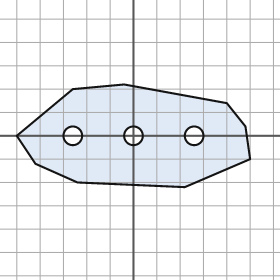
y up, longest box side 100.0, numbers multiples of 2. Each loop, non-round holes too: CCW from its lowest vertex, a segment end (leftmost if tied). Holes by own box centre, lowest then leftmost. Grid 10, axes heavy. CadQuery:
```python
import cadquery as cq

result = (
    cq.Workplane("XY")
    .moveTo(22.0, -22.0)
    .lineTo(50.0, -10.0)
    .lineTo(48.0, 4.0)
    .lineTo(40.0, 14.0)
    .lineTo(-4.0, 22.0)
    .lineTo(-26.0, 20.0)
    .lineTo(-50.0, 0.0)
    .lineTo(-42.0, -12.0)
    .lineTo(-24.0, -20.0)
    .close()
    .moveTo(-26.0, 0.0)
    .circle(4.0)
    .moveTo(0.0, 0.0)
    .circle(4.0)
    .moveTo(26.0, 0.0)
    .circle(4.0)
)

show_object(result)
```